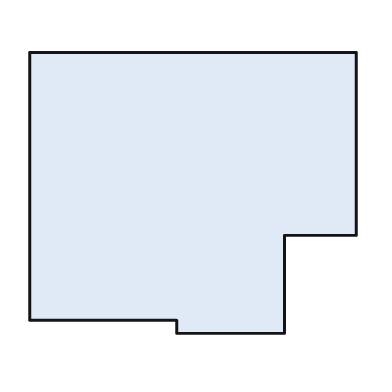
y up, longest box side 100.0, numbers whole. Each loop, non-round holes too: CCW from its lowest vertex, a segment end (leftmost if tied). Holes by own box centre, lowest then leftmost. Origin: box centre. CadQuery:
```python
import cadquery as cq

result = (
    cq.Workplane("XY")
    .moveTo(-5.0, -43.0)
    .lineTo(28.0, -43.0)
    .lineTo(28.0, -13.0)
    .lineTo(50.0, -13.0)
    .lineTo(50.0, 43.0)
    .lineTo(-50.0, 43.0)
    .lineTo(-50.0, -39.0)
    .lineTo(-5.0, -39.0)
    .close()
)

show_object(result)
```